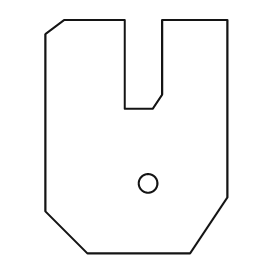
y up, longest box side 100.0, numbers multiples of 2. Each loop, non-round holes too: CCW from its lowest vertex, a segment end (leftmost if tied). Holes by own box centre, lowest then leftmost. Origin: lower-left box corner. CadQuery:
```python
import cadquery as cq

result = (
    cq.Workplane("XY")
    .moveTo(18.0, 0.0)
    .lineTo(62.0, 0.0)
    .lineTo(78.0, 24.0)
    .lineTo(78.0, 100.0)
    .lineTo(50.0, 100.0)
    .lineTo(50.0, 68.0)
    .lineTo(46.0, 62.0)
    .lineTo(34.0, 62.0)
    .lineTo(34.0, 100.0)
    .lineTo(8.0, 100.0)
    .lineTo(0.0, 94.0)
    .lineTo(0.0, 18.0)
    .close()
    .moveTo(44.0, 30.0)
    .circle(4.0)
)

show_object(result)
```